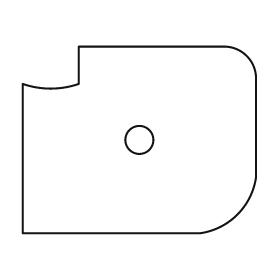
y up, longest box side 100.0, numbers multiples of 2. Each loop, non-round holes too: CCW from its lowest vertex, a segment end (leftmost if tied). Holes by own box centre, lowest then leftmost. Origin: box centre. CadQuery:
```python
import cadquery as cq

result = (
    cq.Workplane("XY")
    .moveTo(-50.0, -40.0)
    .lineTo(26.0, -40.0)
    .threePointArc((42.0, -32.0), (50.0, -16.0))
    .lineTo(50.0, 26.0)
    .threePointArc((46.0, 36.0), (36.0, 40.0))
    .lineTo(-26.0, 40.0)
    .lineTo(-26.0, 24.0)
    .threePointArc((-38.0, 22.0), (-50.0, 24.0))
    .close()
    .moveTo(0.0, 0.0)
    .circle(6.0)
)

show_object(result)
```